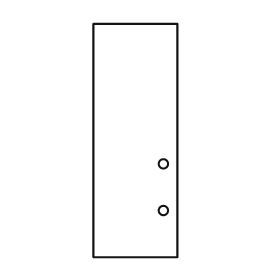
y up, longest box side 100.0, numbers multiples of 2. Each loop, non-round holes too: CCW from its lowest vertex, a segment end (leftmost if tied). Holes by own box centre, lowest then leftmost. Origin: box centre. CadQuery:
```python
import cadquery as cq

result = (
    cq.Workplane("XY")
    .moveTo(-18.0, -50.0)
    .lineTo(18.0, -50.0)
    .lineTo(18.0, 50.0)
    .lineTo(-18.0, 50.0)
    .close()
    .moveTo(12.0, -30.0)
    .circle(2.0)
    .moveTo(12.0, -10.0)
    .circle(2.0)
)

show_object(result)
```